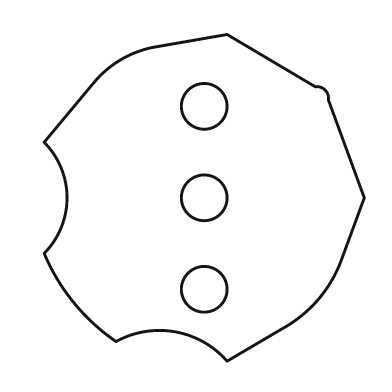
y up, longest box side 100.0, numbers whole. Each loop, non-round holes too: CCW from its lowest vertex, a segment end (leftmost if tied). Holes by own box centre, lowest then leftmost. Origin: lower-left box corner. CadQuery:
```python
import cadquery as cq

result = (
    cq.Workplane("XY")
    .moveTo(56.0, 0.0)
    .lineTo(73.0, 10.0)
    .threePointArc((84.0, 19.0), (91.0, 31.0))
    .lineTo(98.0, 50.0)
    .lineTo(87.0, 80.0)
    .threePointArc((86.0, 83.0), (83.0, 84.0))
    .lineTo(56.0, 100.0)
    .lineTo(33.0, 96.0)
    .threePointArc((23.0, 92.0), (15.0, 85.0))
    .lineTo(0.0, 67.0)
    .threePointArc((7.0, 50.0), (0.0, 33.0))
    .threePointArc((9.0, 18.0), (22.0, 6.0))
    .threePointArc((40.0, 9.0), (56.0, 0.0))
    .close()
    .moveTo(49.0, 22.0)
    .circle(7.0)
    .moveTo(49.0, 50.0)
    .circle(7.0)
    .moveTo(49.0, 78.0)
    .circle(7.0)
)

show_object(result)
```